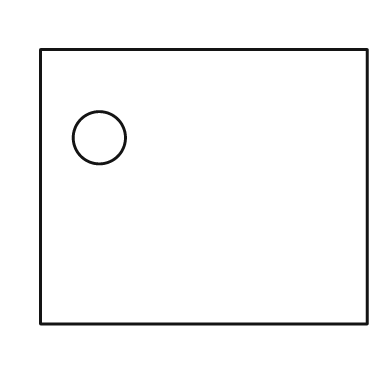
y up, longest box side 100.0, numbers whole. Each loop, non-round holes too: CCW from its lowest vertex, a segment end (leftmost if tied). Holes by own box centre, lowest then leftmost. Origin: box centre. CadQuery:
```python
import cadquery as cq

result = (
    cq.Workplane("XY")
    .moveTo(-50.0, -42.0)
    .lineTo(50.0, -42.0)
    .lineTo(50.0, 42.0)
    .lineTo(-50.0, 42.0)
    .close()
    .moveTo(-32.0, 15.0)
    .circle(8.0)
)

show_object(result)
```